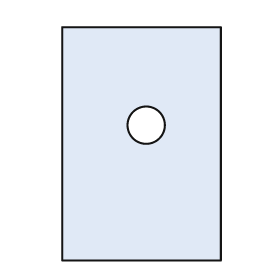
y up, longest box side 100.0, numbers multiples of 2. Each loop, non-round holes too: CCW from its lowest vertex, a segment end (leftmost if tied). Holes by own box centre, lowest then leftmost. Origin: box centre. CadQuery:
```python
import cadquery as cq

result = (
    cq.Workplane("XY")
    .moveTo(-34.0, -50.0)
    .lineTo(34.0, -50.0)
    .lineTo(34.0, 50.0)
    .lineTo(-34.0, 50.0)
    .close()
    .moveTo(2.0, 8.0)
    .circle(8.0)
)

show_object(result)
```